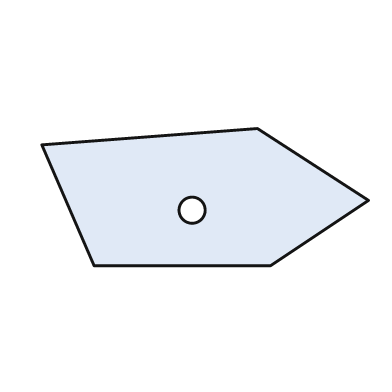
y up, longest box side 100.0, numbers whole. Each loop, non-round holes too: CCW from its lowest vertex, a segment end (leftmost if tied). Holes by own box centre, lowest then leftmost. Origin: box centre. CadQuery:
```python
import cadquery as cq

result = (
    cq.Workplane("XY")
    .moveTo(-34.0, -21.0)
    .lineTo(20.0, -21.0)
    .lineTo(50.0, -1.0)
    .lineTo(16.0, 21.0)
    .lineTo(-50.0, 16.0)
    .close()
    .moveTo(-4.0, -4.0)
    .circle(4.0)
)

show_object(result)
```